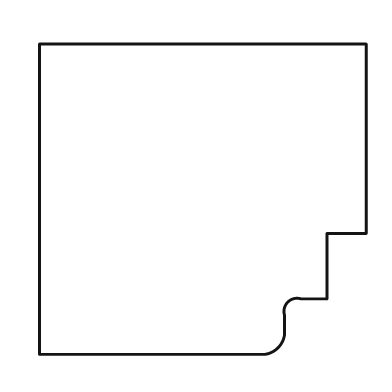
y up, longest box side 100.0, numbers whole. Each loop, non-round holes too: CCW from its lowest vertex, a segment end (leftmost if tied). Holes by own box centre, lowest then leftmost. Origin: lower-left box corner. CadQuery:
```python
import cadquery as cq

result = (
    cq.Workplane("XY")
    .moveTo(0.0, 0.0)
    .lineTo(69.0, 0.0)
    .threePointArc((73.0, 2.0), (75.0, 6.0))
    .lineTo(75.0, 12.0)
    .threePointArc((76.0, 16.0), (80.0, 17.0))
    .lineTo(88.0, 17.0)
    .lineTo(88.0, 37.0)
    .lineTo(100.0, 37.0)
    .lineTo(100.0, 95.0)
    .lineTo(0.0, 95.0)
    .close()
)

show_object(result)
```